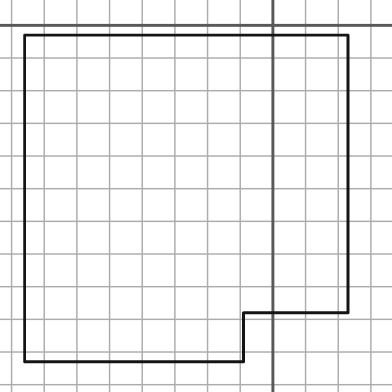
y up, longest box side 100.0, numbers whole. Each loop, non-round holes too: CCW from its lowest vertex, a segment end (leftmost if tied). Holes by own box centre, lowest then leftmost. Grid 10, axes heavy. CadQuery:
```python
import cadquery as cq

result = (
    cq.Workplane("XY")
    .moveTo(-76.0, -103.0)
    .lineTo(-9.0, -103.0)
    .lineTo(-9.0, -88.0)
    .lineTo(23.0, -88.0)
    .lineTo(23.0, -3.0)
    .lineTo(-76.0, -3.0)
    .close()
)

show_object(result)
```